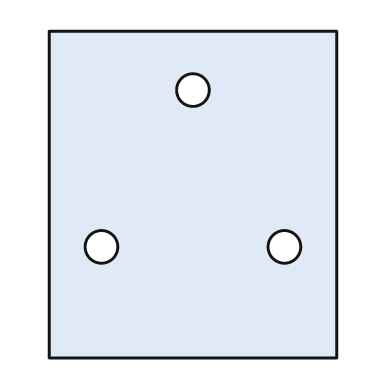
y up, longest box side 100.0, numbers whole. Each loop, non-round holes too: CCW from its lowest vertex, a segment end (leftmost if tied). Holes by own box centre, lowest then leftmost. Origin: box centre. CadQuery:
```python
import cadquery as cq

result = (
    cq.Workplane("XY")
    .moveTo(-44.0, -50.0)
    .lineTo(44.0, -50.0)
    .lineTo(44.0, 50.0)
    .lineTo(-44.0, 50.0)
    .close()
    .moveTo(-28.0, -16.0)
    .circle(5.0)
    .moveTo(28.0, -16.0)
    .circle(5.0)
    .moveTo(0.0, 32.0)
    .circle(5.0)
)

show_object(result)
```